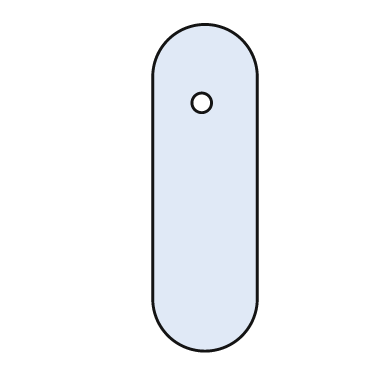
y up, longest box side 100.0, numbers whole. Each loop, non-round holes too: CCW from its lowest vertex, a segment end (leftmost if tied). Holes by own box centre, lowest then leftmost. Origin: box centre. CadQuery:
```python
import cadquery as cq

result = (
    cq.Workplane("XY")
    .moveTo(-16.0, -34.0)
    .threePointArc((0.0, -50.0), (16.0, -34.0))
    .lineTo(16.0, 34.0)
    .threePointArc((0.0, 50.0), (-16.0, 34.0))
    .close()
    .moveTo(-1.0, 26.0)
    .circle(3.0)
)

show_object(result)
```